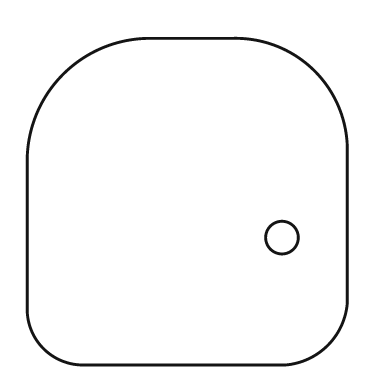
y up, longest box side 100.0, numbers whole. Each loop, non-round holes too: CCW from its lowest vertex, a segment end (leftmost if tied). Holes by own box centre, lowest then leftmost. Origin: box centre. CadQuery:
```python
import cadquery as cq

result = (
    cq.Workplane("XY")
    .moveTo(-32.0, -50.0)
    .lineTo(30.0, -50.0)
    .threePointArc((43.0, -44.0), (49.0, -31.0))
    .lineTo(49.0, 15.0)
    .threePointArc((39.0, 40.0), (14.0, 50.0))
    .lineTo(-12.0, 50.0)
    .threePointArc((-38.0, 39.0), (-49.0, 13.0))
    .lineTo(-49.0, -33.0)
    .threePointArc((-44.0, -45.0), (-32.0, -50.0))
    .close()
    .moveTo(29.0, -11.0)
    .circle(5.0)
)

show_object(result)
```